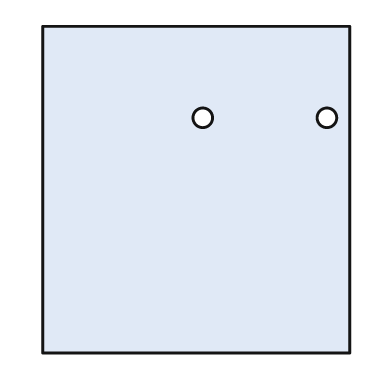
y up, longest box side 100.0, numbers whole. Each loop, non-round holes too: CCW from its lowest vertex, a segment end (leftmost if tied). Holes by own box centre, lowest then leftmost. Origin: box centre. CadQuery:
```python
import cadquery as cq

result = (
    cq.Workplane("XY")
    .moveTo(-47.0, -50.0)
    .lineTo(47.0, -50.0)
    .lineTo(47.0, 50.0)
    .lineTo(-47.0, 50.0)
    .close()
    .moveTo(2.0, 22.0)
    .circle(3.0)
    .moveTo(40.0, 22.0)
    .circle(3.0)
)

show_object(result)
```